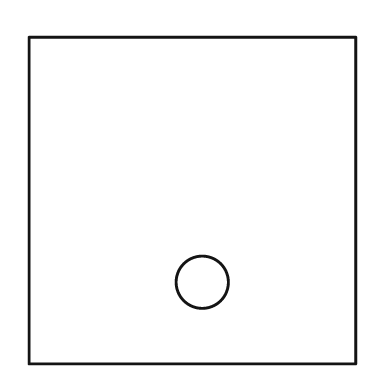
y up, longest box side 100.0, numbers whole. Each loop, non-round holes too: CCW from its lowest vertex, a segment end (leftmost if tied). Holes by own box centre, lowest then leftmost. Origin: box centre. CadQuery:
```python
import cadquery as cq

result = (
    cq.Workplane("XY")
    .moveTo(-50.0, -50.0)
    .lineTo(50.0, -50.0)
    .lineTo(50.0, 50.0)
    .lineTo(-50.0, 50.0)
    .close()
    .moveTo(3.0, -25.0)
    .circle(8.0)
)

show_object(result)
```